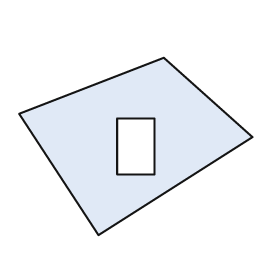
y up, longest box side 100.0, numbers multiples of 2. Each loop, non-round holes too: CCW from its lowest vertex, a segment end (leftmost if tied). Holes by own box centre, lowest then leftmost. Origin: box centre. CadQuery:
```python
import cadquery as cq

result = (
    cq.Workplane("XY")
    .moveTo(-16.0, -38.0)
    .lineTo(50.0, 4.0)
    .lineTo(12.0, 38.0)
    .lineTo(-50.0, 14.0)
    .close()
    .moveTo(-8.0, -12.0)
    .lineTo(8.0, -12.0)
    .lineTo(8.0, 12.0)
    .lineTo(-8.0, 12.0)
    .close()
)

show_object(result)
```